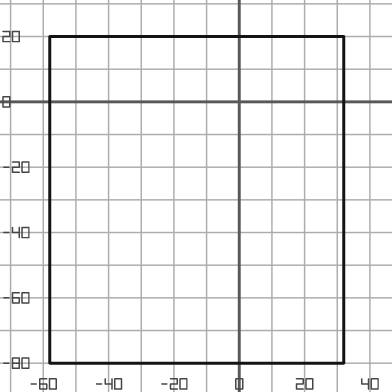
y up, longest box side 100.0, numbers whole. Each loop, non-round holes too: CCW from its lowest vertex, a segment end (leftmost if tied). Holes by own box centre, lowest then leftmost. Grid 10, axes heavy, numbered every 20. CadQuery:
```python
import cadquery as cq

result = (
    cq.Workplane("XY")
    .moveTo(-58.0, -80.0)
    .lineTo(32.0, -80.0)
    .lineTo(32.0, 20.0)
    .lineTo(-58.0, 20.0)
    .close()
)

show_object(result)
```